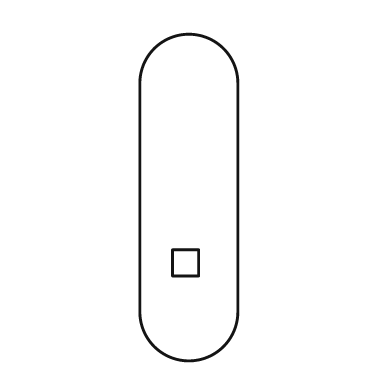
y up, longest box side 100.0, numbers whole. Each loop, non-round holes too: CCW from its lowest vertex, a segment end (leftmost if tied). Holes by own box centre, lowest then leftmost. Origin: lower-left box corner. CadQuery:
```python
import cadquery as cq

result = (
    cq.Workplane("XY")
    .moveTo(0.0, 15.0)
    .threePointArc((15.0, 0.0), (30.0, 15.0))
    .lineTo(30.0, 85.0)
    .threePointArc((15.0, 100.0), (0.0, 85.0))
    .close()
    .moveTo(10.0, 26.0)
    .lineTo(18.0, 26.0)
    .lineTo(18.0, 34.0)
    .lineTo(10.0, 34.0)
    .close()
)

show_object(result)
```